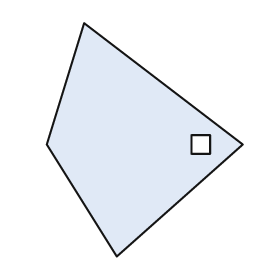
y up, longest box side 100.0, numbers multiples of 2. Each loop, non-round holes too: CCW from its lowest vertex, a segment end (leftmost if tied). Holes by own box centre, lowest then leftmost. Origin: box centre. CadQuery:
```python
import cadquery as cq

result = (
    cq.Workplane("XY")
    .moveTo(-12.0, -50.0)
    .lineTo(42.0, -2.0)
    .lineTo(-26.0, 50.0)
    .lineTo(-42.0, -2.0)
    .close()
    .moveTo(20.0, -6.0)
    .lineTo(28.0, -6.0)
    .lineTo(28.0, 2.0)
    .lineTo(20.0, 2.0)
    .close()
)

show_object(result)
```